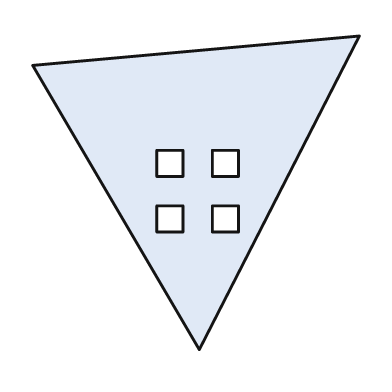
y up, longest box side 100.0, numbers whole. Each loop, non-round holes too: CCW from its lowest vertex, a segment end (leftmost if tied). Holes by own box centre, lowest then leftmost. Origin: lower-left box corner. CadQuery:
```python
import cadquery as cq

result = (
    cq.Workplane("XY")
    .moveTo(51.0, 0.0)
    .lineTo(100.0, 96.0)
    .lineTo(0.0, 87.0)
    .close()
    .moveTo(38.0, 36.0)
    .lineTo(46.0, 36.0)
    .lineTo(46.0, 44.0)
    .lineTo(38.0, 44.0)
    .close()
    .moveTo(55.0, 36.0)
    .lineTo(63.0, 36.0)
    .lineTo(63.0, 44.0)
    .lineTo(55.0, 44.0)
    .close()
    .moveTo(38.0, 53.0)
    .lineTo(46.0, 53.0)
    .lineTo(46.0, 61.0)
    .lineTo(38.0, 61.0)
    .close()
    .moveTo(55.0, 53.0)
    .lineTo(63.0, 53.0)
    .lineTo(63.0, 61.0)
    .lineTo(55.0, 61.0)
    .close()
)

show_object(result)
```